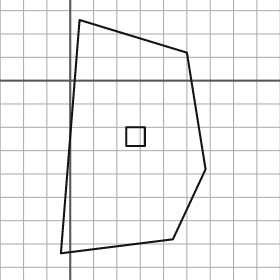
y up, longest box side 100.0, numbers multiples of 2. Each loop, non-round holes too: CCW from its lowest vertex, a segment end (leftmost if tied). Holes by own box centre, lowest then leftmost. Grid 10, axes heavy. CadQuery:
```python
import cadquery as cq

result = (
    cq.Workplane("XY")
    .moveTo(-4.0, -74.0)
    .lineTo(44.0, -68.0)
    .lineTo(58.0, -38.0)
    .lineTo(50.0, 12.0)
    .lineTo(4.0, 26.0)
    .close()
    .moveTo(24.0, -28.0)
    .lineTo(32.0, -28.0)
    .lineTo(32.0, -20.0)
    .lineTo(24.0, -20.0)
    .close()
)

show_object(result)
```